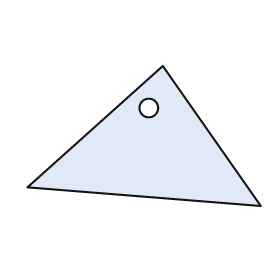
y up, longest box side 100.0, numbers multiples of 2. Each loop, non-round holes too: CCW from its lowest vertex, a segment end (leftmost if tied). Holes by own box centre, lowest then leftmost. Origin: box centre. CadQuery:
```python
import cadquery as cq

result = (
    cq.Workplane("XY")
    .moveTo(50.0, -30.0)
    .lineTo(8.0, 30.0)
    .lineTo(-50.0, -22.0)
    .close()
    .moveTo(2.0, 12.0)
    .circle(4.0)
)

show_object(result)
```